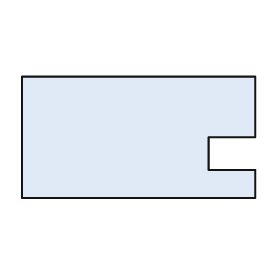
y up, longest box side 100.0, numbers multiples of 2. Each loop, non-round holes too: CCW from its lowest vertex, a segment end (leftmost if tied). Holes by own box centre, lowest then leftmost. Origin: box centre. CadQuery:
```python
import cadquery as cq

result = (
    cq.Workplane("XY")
    .moveTo(-50.0, -26.0)
    .lineTo(50.0, -26.0)
    .lineTo(50.0, -14.0)
    .lineTo(30.0, -14.0)
    .lineTo(30.0, 0.0)
    .lineTo(50.0, 0.0)
    .lineTo(50.0, 26.0)
    .lineTo(-50.0, 26.0)
    .close()
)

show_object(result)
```